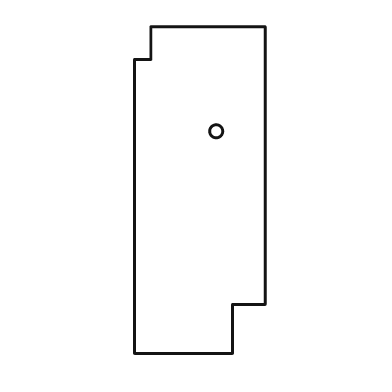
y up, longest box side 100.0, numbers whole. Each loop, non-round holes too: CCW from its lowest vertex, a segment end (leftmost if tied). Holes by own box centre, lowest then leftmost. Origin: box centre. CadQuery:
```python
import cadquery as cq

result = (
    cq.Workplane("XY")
    .moveTo(-20.0, -50.0)
    .lineTo(10.0, -50.0)
    .lineTo(10.0, -35.0)
    .lineTo(20.0, -35.0)
    .lineTo(20.0, 50.0)
    .lineTo(-15.0, 50.0)
    .lineTo(-15.0, 40.0)
    .lineTo(-20.0, 40.0)
    .close()
    .moveTo(5.0, 18.0)
    .circle(2.0)
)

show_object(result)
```